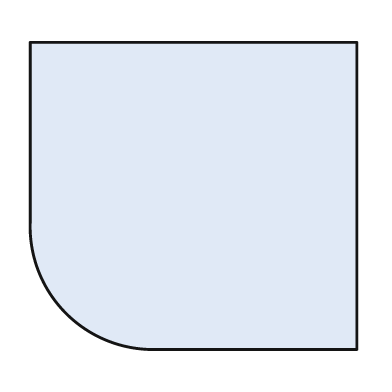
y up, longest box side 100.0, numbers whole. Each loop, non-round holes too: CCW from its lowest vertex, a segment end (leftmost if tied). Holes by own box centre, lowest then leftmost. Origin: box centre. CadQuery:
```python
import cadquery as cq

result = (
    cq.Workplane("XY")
    .moveTo(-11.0, -47.0)
    .lineTo(50.0, -47.0)
    .lineTo(50.0, 47.0)
    .lineTo(-50.0, 47.0)
    .lineTo(-50.0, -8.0)
    .threePointArc((-39.0, -36.0), (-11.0, -47.0))
    .close()
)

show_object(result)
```